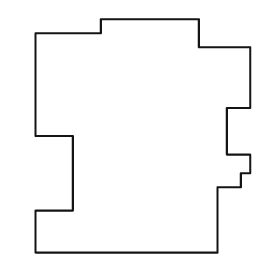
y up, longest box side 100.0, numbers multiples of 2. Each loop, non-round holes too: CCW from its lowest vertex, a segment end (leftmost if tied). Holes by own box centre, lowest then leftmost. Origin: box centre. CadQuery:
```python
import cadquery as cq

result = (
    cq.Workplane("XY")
    .moveTo(-46.0, -50.0)
    .lineTo(32.0, -50.0)
    .lineTo(32.0, -22.0)
    .lineTo(42.0, -22.0)
    .lineTo(42.0, -16.0)
    .lineTo(46.0, -16.0)
    .lineTo(46.0, -8.0)
    .lineTo(36.0, -8.0)
    .lineTo(36.0, 12.0)
    .lineTo(46.0, 12.0)
    .lineTo(46.0, 38.0)
    .lineTo(24.0, 38.0)
    .lineTo(24.0, 50.0)
    .lineTo(-18.0, 50.0)
    .lineTo(-18.0, 44.0)
    .lineTo(-46.0, 44.0)
    .lineTo(-46.0, 0.0)
    .lineTo(-30.0, 0.0)
    .lineTo(-30.0, -32.0)
    .lineTo(-46.0, -32.0)
    .close()
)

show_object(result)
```